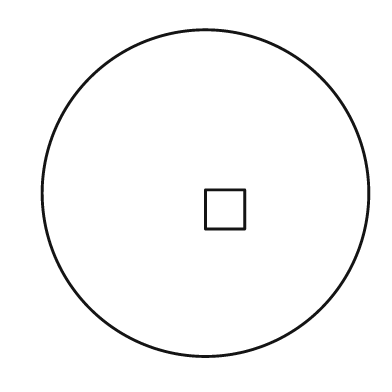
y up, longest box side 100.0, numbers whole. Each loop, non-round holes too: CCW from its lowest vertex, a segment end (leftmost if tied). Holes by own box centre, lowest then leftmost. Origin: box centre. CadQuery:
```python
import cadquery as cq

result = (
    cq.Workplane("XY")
    .moveTo(0.0, 0.0)
    .circle(50.0)
    .moveTo(0.0, -11.0)
    .lineTo(12.0, -11.0)
    .lineTo(12.0, 1.0)
    .lineTo(0.0, 1.0)
    .close()
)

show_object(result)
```